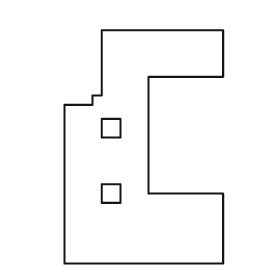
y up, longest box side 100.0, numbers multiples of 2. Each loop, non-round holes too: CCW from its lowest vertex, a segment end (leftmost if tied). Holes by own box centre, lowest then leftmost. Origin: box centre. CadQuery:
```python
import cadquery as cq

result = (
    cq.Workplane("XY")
    .moveTo(-34.0, -50.0)
    .lineTo(34.0, -50.0)
    .lineTo(34.0, -20.0)
    .lineTo(2.0, -20.0)
    .lineTo(2.0, 30.0)
    .lineTo(34.0, 30.0)
    .lineTo(34.0, 50.0)
    .lineTo(-18.0, 50.0)
    .lineTo(-18.0, 22.0)
    .lineTo(-22.0, 22.0)
    .lineTo(-22.0, 18.0)
    .lineTo(-34.0, 18.0)
    .close()
    .moveTo(-18.0, -24.0)
    .lineTo(-10.0, -24.0)
    .lineTo(-10.0, -16.0)
    .lineTo(-18.0, -16.0)
    .close()
    .moveTo(-18.0, 4.0)
    .lineTo(-10.0, 4.0)
    .lineTo(-10.0, 12.0)
    .lineTo(-18.0, 12.0)
    .close()
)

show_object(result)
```